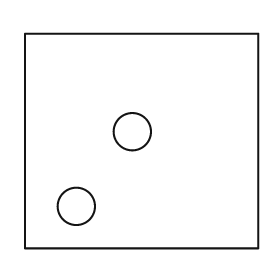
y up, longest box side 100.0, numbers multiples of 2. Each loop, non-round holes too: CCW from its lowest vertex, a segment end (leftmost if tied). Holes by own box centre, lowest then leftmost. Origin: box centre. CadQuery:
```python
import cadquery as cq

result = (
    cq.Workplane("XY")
    .moveTo(-50.0, -46.0)
    .lineTo(50.0, -46.0)
    .lineTo(50.0, 46.0)
    .lineTo(-50.0, 46.0)
    .close()
    .moveTo(-28.0, -28.0)
    .circle(8.0)
    .moveTo(-4.0, 4.0)
    .circle(8.0)
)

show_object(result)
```